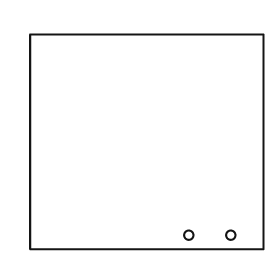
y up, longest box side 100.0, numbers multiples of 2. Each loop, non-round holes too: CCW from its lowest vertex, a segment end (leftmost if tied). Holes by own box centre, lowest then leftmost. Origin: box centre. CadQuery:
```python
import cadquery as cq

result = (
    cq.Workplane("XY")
    .moveTo(-50.0, -46.0)
    .lineTo(50.0, -46.0)
    .lineTo(50.0, 46.0)
    .lineTo(-50.0, 46.0)
    .close()
    .moveTo(18.0, -40.0)
    .circle(2.0)
    .moveTo(36.0, -40.0)
    .circle(2.0)
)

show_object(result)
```